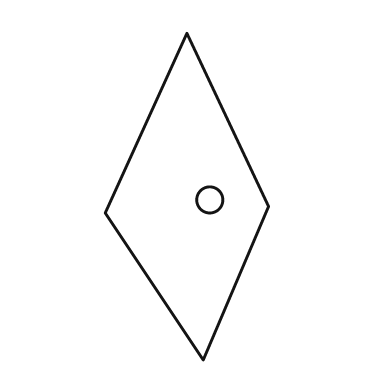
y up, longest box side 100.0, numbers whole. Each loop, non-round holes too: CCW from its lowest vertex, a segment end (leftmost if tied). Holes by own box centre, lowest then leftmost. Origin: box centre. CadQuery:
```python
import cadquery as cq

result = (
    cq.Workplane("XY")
    .moveTo(5.0, -50.0)
    .lineTo(25.0, -3.0)
    .lineTo(0.0, 50.0)
    .lineTo(-25.0, -5.0)
    .close()
    .moveTo(7.0, -1.0)
    .circle(4.0)
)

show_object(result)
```